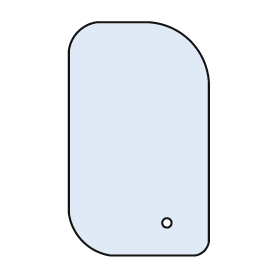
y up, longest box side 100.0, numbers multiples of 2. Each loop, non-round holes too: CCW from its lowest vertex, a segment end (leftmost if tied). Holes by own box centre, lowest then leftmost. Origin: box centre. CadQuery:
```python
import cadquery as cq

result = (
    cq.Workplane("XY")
    .moveTo(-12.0, -50.0)
    .lineTo(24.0, -50.0)
    .threePointArc((28.0, -48.0), (30.0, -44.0))
    .lineTo(30.0, 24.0)
    .threePointArc((22.0, 42.0), (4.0, 50.0))
    .lineTo(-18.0, 50.0)
    .threePointArc((-26.0, 46.0), (-30.0, 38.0))
    .lineTo(-30.0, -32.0)
    .threePointArc((-24.0, -44.0), (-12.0, -50.0))
    .close()
    .moveTo(12.0, -36.0)
    .circle(2.0)
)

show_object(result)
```